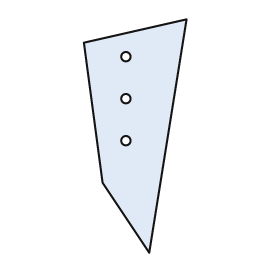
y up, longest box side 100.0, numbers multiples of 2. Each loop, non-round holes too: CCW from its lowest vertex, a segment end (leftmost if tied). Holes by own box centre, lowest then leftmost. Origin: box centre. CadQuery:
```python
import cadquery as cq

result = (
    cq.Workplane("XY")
    .moveTo(6.0, -50.0)
    .lineTo(22.0, 50.0)
    .lineTo(-22.0, 40.0)
    .lineTo(-14.0, -20.0)
    .close()
    .moveTo(-4.0, -2.0)
    .circle(2.0)
    .moveTo(-4.0, 16.0)
    .circle(2.0)
    .moveTo(-4.0, 34.0)
    .circle(2.0)
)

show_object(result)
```